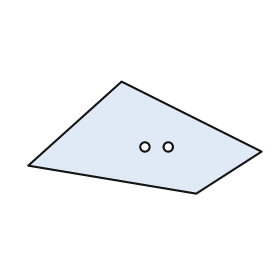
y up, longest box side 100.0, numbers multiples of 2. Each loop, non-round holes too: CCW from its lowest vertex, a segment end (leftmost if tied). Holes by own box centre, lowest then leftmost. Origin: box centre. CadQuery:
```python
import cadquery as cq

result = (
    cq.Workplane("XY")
    .moveTo(22.0, -24.0)
    .lineTo(50.0, -6.0)
    .lineTo(-10.0, 24.0)
    .lineTo(-50.0, -12.0)
    .close()
    .moveTo(0.0, -4.0)
    .circle(2.0)
    .moveTo(10.0, -4.0)
    .circle(2.0)
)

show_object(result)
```